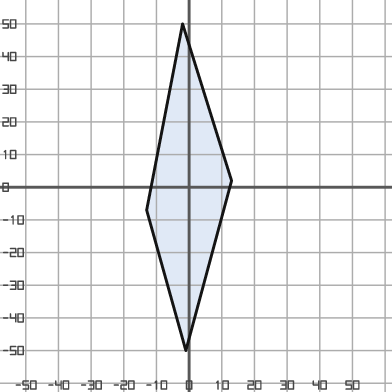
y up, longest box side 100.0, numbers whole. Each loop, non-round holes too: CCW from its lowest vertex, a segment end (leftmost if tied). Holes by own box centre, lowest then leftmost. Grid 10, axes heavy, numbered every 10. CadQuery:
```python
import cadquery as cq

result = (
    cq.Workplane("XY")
    .moveTo(-1.0, -50.0)
    .lineTo(13.0, 2.0)
    .lineTo(-2.0, 50.0)
    .lineTo(-13.0, -7.0)
    .close()
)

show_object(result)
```